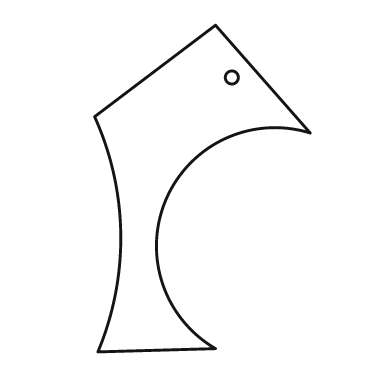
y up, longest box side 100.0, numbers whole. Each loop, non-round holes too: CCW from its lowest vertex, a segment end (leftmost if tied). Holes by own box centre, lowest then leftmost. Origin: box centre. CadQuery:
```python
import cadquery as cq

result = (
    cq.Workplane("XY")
    .moveTo(-32.0, -50.0)
    .lineTo(4.0, -49.0)
    .threePointArc((-11.0, -3.0), (33.0, 17.0))
    .lineTo(4.0, 50.0)
    .lineTo(-33.0, 22.0)
    .threePointArc((-25.0, -14.0), (-32.0, -50.0))
    .close()
    .moveTo(9.0, 34.0)
    .circle(2.0)
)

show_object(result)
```